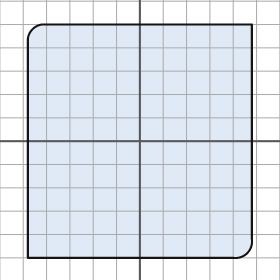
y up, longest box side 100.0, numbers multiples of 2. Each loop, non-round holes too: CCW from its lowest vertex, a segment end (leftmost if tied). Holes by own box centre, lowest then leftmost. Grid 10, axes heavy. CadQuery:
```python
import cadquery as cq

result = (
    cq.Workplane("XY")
    .moveTo(-48.0, -50.0)
    .lineTo(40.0, -50.0)
    .threePointArc((46.0, -48.0), (48.0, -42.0))
    .lineTo(48.0, 50.0)
    .lineTo(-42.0, 50.0)
    .threePointArc((-46.0, 48.0), (-48.0, 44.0))
    .close()
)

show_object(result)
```